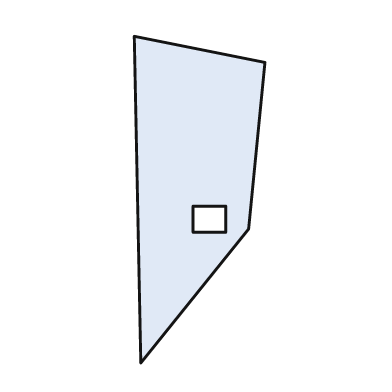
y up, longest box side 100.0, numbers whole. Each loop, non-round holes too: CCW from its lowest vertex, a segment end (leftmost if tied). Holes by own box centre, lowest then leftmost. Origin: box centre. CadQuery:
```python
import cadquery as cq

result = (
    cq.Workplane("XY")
    .moveTo(-18.0, -50.0)
    .lineTo(15.0, -9.0)
    .lineTo(20.0, 42.0)
    .lineTo(-20.0, 50.0)
    .close()
    .moveTo(-2.0, -10.0)
    .lineTo(8.0, -10.0)
    .lineTo(8.0, -2.0)
    .lineTo(-2.0, -2.0)
    .close()
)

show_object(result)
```